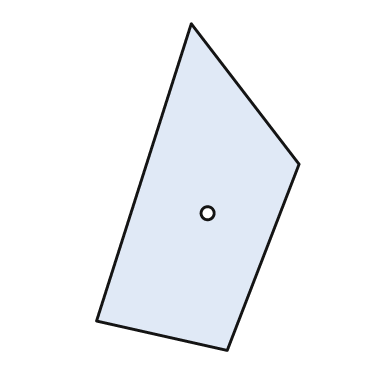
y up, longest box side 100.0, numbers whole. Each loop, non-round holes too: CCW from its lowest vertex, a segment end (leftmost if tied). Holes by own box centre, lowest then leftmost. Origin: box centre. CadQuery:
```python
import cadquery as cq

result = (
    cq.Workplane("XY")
    .moveTo(9.0, -50.0)
    .lineTo(31.0, 7.0)
    .lineTo(-2.0, 50.0)
    .lineTo(-31.0, -41.0)
    .close()
    .moveTo(3.0, -8.0)
    .circle(2.0)
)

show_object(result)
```